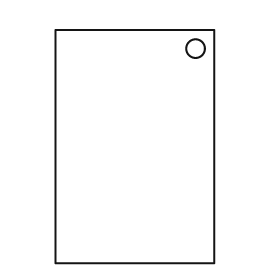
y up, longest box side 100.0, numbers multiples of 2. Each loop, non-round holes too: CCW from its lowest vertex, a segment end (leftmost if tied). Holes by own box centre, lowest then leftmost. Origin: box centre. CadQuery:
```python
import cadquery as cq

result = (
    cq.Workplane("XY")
    .moveTo(-34.0, -50.0)
    .lineTo(34.0, -50.0)
    .lineTo(34.0, 50.0)
    .lineTo(-34.0, 50.0)
    .close()
    .moveTo(26.0, 42.0)
    .circle(4.0)
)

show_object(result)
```